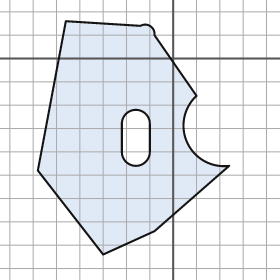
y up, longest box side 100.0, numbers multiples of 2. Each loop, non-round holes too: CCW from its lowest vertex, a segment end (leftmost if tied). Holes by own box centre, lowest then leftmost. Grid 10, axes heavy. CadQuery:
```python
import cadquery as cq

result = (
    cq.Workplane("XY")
    .moveTo(-30.0, -84.0)
    .lineTo(-8.0, -74.0)
    .lineTo(24.0, -46.0)
    .threePointArc((6.0, -36.0), (10.0, -16.0))
    .lineTo(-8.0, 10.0)
    .threePointArc((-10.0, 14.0), (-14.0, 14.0))
    .lineTo(-46.0, 16.0)
    .lineTo(-58.0, -48.0)
    .close()
    .moveTo(-22.0, -40.0)
    .threePointArc((-16.0, -46.0), (-10.0, -40.0))
    .lineTo(-10.0, -28.0)
    .threePointArc((-16.0, -22.0), (-22.0, -28.0))
    .close()
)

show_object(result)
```